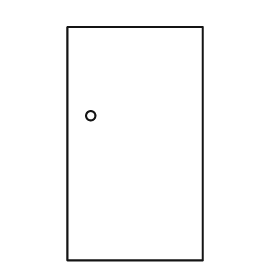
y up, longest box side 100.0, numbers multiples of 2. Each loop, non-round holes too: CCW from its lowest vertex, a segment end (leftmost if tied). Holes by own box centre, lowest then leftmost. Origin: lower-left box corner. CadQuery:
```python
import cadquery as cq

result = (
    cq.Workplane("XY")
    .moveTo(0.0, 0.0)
    .lineTo(58.0, 0.0)
    .lineTo(58.0, 100.0)
    .lineTo(0.0, 100.0)
    .close()
    .moveTo(10.0, 62.0)
    .circle(2.0)
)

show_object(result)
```